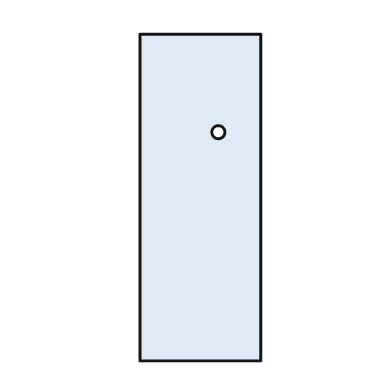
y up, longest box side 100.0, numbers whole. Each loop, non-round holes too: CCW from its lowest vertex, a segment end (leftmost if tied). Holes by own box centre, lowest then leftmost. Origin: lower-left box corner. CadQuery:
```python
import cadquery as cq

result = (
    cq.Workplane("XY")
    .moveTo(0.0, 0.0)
    .lineTo(37.0, 0.0)
    .lineTo(37.0, 100.0)
    .lineTo(0.0, 100.0)
    .close()
    .moveTo(24.0, 70.0)
    .circle(2.0)
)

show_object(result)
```